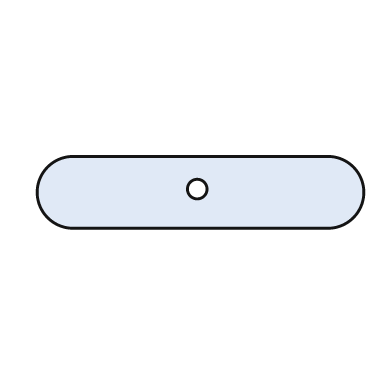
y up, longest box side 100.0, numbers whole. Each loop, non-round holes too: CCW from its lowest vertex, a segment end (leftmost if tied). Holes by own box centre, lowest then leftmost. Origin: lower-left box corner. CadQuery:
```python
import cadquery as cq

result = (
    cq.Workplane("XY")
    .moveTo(11.0, 0.0)
    .lineTo(89.0, 0.0)
    .threePointArc((100.0, 11.0), (89.0, 22.0))
    .lineTo(11.0, 22.0)
    .threePointArc((0.0, 11.0), (11.0, 0.0))
    .close()
    .moveTo(49.0, 12.0)
    .circle(3.0)
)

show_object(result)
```